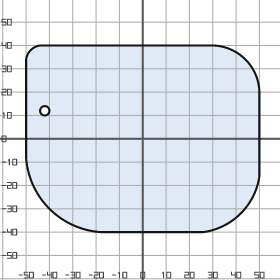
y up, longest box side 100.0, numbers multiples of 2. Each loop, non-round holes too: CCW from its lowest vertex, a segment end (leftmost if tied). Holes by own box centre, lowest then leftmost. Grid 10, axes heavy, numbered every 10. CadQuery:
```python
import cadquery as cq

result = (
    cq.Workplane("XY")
    .moveTo(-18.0, -40.0)
    .lineTo(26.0, -40.0)
    .threePointArc((42.0, -32.0), (50.0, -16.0))
    .lineTo(50.0, 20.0)
    .threePointArc((44.0, 34.0), (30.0, 40.0))
    .lineTo(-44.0, 40.0)
    .threePointArc((-48.0, 38.0), (-50.0, 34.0))
    .lineTo(-50.0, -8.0)
    .threePointArc((-40.0, -30.0), (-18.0, -40.0))
    .close()
    .moveTo(-42.0, 12.0)
    .circle(2.0)
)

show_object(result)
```